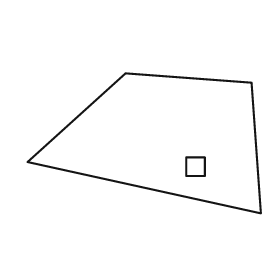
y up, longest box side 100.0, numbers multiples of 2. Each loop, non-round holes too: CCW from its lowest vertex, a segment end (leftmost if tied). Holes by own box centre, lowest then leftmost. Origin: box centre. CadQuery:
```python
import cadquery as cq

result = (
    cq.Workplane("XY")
    .moveTo(50.0, -30.0)
    .lineTo(46.0, 26.0)
    .lineTo(-8.0, 30.0)
    .lineTo(-50.0, -8.0)
    .close()
    .moveTo(18.0, -14.0)
    .lineTo(26.0, -14.0)
    .lineTo(26.0, -6.0)
    .lineTo(18.0, -6.0)
    .close()
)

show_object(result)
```